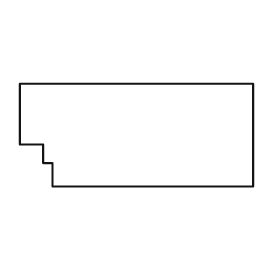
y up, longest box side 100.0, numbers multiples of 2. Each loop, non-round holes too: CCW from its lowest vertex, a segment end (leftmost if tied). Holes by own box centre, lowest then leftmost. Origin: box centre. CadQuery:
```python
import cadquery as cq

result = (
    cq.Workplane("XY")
    .moveTo(-36.0, -22.0)
    .lineTo(50.0, -22.0)
    .lineTo(50.0, 22.0)
    .lineTo(-50.0, 22.0)
    .lineTo(-50.0, -4.0)
    .lineTo(-40.0, -4.0)
    .lineTo(-40.0, -12.0)
    .lineTo(-36.0, -12.0)
    .close()
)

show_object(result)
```